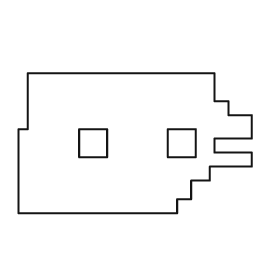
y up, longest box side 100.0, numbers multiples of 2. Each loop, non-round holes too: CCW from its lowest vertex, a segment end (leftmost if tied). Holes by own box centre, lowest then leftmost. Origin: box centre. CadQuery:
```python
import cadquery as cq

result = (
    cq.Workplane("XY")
    .moveTo(-50.0, -30.0)
    .lineTo(18.0, -30.0)
    .lineTo(18.0, -24.0)
    .lineTo(24.0, -24.0)
    .lineTo(24.0, -16.0)
    .lineTo(32.0, -16.0)
    .lineTo(32.0, -10.0)
    .lineTo(50.0, -10.0)
    .lineTo(50.0, -4.0)
    .lineTo(34.0, -4.0)
    .lineTo(34.0, 2.0)
    .lineTo(50.0, 2.0)
    .lineTo(50.0, 12.0)
    .lineTo(40.0, 12.0)
    .lineTo(40.0, 18.0)
    .lineTo(34.0, 18.0)
    .lineTo(34.0, 30.0)
    .lineTo(-46.0, 30.0)
    .lineTo(-46.0, 6.0)
    .lineTo(-50.0, 6.0)
    .close()
    .moveTo(-24.0, -6.0)
    .lineTo(-12.0, -6.0)
    .lineTo(-12.0, 6.0)
    .lineTo(-24.0, 6.0)
    .close()
    .moveTo(14.0, -6.0)
    .lineTo(26.0, -6.0)
    .lineTo(26.0, 6.0)
    .lineTo(14.0, 6.0)
    .close()
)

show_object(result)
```